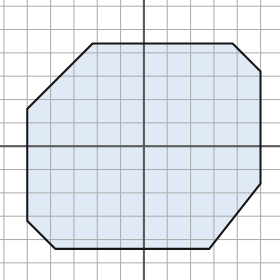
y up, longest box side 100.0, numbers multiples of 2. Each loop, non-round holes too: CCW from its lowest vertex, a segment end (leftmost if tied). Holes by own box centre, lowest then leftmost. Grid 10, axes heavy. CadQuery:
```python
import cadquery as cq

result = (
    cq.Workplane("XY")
    .moveTo(-38.0, -44.0)
    .lineTo(28.0, -44.0)
    .lineTo(50.0, -16.0)
    .lineTo(50.0, 32.0)
    .lineTo(38.0, 44.0)
    .lineTo(-22.0, 44.0)
    .lineTo(-50.0, 16.0)
    .lineTo(-50.0, -32.0)
    .close()
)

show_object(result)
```